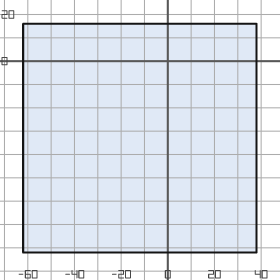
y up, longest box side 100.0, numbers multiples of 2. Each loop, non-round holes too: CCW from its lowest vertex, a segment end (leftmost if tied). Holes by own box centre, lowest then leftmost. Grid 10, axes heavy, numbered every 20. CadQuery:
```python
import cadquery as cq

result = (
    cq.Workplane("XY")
    .moveTo(-62.0, -82.0)
    .lineTo(38.0, -82.0)
    .lineTo(38.0, 16.0)
    .lineTo(-62.0, 16.0)
    .close()
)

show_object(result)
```